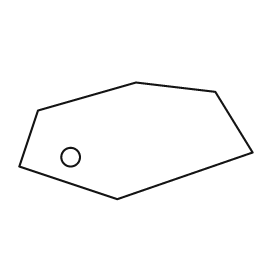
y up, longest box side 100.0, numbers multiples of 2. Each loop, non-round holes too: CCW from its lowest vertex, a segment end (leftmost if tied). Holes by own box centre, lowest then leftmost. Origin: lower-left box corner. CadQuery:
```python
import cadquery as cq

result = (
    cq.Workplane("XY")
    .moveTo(42.0, 0.0)
    .lineTo(100.0, 20.0)
    .lineTo(84.0, 46.0)
    .lineTo(50.0, 50.0)
    .lineTo(8.0, 38.0)
    .lineTo(0.0, 14.0)
    .close()
    .moveTo(22.0, 18.0)
    .circle(4.0)
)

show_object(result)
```